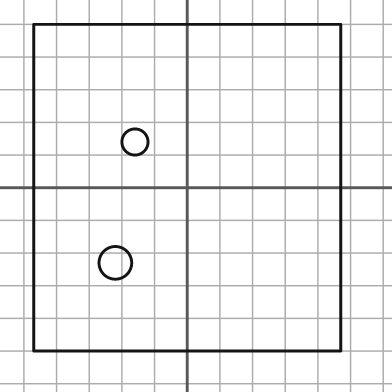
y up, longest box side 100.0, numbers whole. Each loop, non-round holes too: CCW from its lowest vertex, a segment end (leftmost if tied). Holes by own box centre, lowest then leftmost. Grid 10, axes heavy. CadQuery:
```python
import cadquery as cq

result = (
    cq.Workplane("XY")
    .moveTo(-47.0, -50.0)
    .lineTo(47.0, -50.0)
    .lineTo(47.0, 50.0)
    .lineTo(-47.0, 50.0)
    .close()
    .moveTo(-22.0, -23.0)
    .circle(5.0)
    .moveTo(-16.0, 14.0)
    .circle(4.0)
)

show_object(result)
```